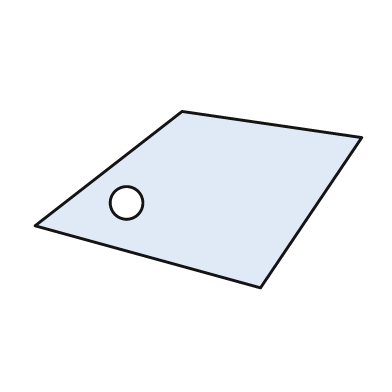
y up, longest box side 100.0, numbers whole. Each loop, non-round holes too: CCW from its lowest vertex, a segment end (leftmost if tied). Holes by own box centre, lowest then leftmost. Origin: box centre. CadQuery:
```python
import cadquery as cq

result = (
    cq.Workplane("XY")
    .moveTo(19.0, -27.0)
    .lineTo(50.0, 19.0)
    .lineTo(-5.0, 27.0)
    .lineTo(-50.0, -8.0)
    .close()
    .moveTo(-22.0, -1.0)
    .circle(5.0)
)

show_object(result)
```